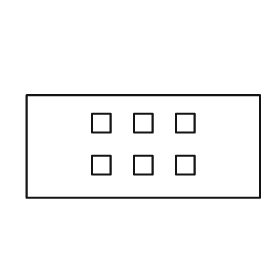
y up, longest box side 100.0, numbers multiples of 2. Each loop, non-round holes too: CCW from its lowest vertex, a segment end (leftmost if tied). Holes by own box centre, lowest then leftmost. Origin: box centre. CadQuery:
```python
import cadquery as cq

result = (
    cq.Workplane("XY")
    .moveTo(-50.0, -22.0)
    .lineTo(50.0, -22.0)
    .lineTo(50.0, 22.0)
    .lineTo(-50.0, 22.0)
    .close()
    .moveTo(-22.0, -12.0)
    .lineTo(-14.0, -12.0)
    .lineTo(-14.0, -4.0)
    .lineTo(-22.0, -4.0)
    .close()
    .moveTo(-4.0, -12.0)
    .lineTo(4.0, -12.0)
    .lineTo(4.0, -4.0)
    .lineTo(-4.0, -4.0)
    .close()
    .moveTo(14.0, -12.0)
    .lineTo(22.0, -12.0)
    .lineTo(22.0, -4.0)
    .lineTo(14.0, -4.0)
    .close()
    .moveTo(-22.0, 6.0)
    .lineTo(-14.0, 6.0)
    .lineTo(-14.0, 14.0)
    .lineTo(-22.0, 14.0)
    .close()
    .moveTo(-4.0, 6.0)
    .lineTo(4.0, 6.0)
    .lineTo(4.0, 14.0)
    .lineTo(-4.0, 14.0)
    .close()
    .moveTo(14.0, 6.0)
    .lineTo(22.0, 6.0)
    .lineTo(22.0, 14.0)
    .lineTo(14.0, 14.0)
    .close()
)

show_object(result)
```